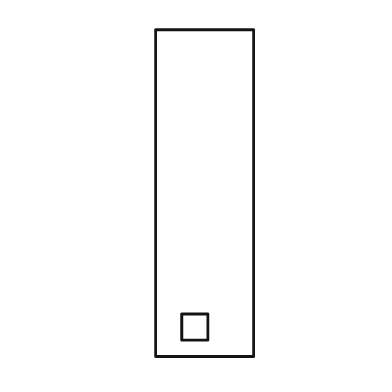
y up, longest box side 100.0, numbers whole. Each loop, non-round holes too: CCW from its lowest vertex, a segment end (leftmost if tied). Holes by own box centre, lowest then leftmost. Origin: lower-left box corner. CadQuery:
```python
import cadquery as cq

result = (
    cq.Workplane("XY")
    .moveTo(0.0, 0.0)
    .lineTo(30.0, 0.0)
    .lineTo(30.0, 100.0)
    .lineTo(0.0, 100.0)
    .close()
    .moveTo(8.0, 5.0)
    .lineTo(16.0, 5.0)
    .lineTo(16.0, 13.0)
    .lineTo(8.0, 13.0)
    .close()
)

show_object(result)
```